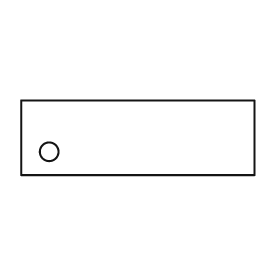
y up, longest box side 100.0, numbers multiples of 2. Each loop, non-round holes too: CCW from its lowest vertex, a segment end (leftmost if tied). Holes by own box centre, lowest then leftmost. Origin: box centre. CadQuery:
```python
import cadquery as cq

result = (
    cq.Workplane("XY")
    .moveTo(-50.0, -16.0)
    .lineTo(50.0, -16.0)
    .lineTo(50.0, 16.0)
    .lineTo(-50.0, 16.0)
    .close()
    .moveTo(-38.0, -6.0)
    .circle(4.0)
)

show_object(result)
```